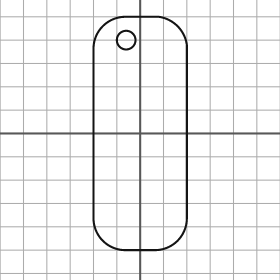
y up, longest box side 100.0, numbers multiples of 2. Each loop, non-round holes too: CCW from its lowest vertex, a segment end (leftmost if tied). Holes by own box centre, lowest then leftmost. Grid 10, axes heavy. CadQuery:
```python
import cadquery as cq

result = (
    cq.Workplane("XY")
    .moveTo(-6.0, -50.0)
    .lineTo(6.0, -50.0)
    .threePointArc((16.0, -46.0), (20.0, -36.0))
    .lineTo(20.0, 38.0)
    .threePointArc((16.0, 46.0), (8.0, 50.0))
    .lineTo(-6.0, 50.0)
    .threePointArc((-16.0, 46.0), (-20.0, 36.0))
    .lineTo(-20.0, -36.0)
    .threePointArc((-16.0, -46.0), (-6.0, -50.0))
    .close()
    .moveTo(-6.0, 40.0)
    .circle(4.0)
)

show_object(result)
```